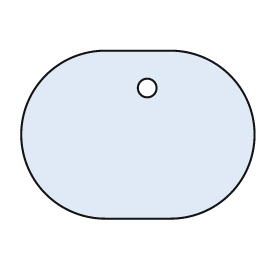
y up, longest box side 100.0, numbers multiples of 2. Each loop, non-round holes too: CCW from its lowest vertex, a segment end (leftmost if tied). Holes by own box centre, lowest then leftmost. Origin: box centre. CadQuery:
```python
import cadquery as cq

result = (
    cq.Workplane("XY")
    .moveTo(-14.0, -36.0)
    .lineTo(14.0, -36.0)
    .threePointArc((50.0, 0.0), (14.0, 36.0))
    .lineTo(-14.0, 36.0)
    .threePointArc((-50.0, 0.0), (-14.0, -36.0))
    .close()
    .moveTo(4.0, 20.0)
    .circle(4.0)
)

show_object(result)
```